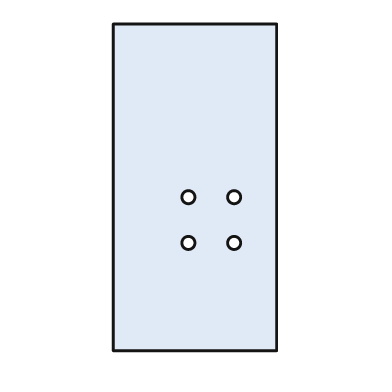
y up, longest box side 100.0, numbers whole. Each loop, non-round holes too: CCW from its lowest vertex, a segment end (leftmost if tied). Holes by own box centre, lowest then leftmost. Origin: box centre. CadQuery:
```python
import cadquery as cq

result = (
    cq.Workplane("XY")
    .moveTo(-25.0, -50.0)
    .lineTo(25.0, -50.0)
    .lineTo(25.0, 50.0)
    .lineTo(-25.0, 50.0)
    .close()
    .moveTo(-2.0, -17.0)
    .circle(2.0)
    .moveTo(12.0, -17.0)
    .circle(2.0)
    .moveTo(-2.0, -3.0)
    .circle(2.0)
    .moveTo(12.0, -3.0)
    .circle(2.0)
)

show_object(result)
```